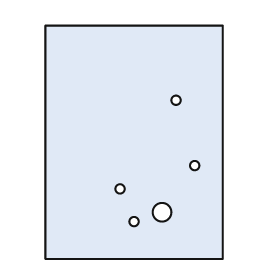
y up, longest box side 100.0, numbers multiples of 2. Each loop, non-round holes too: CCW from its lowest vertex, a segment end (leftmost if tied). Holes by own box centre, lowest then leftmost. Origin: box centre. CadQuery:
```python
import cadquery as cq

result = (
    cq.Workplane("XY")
    .moveTo(-38.0, -50.0)
    .lineTo(38.0, -50.0)
    .lineTo(38.0, 50.0)
    .lineTo(-38.0, 50.0)
    .close()
    .moveTo(0.0, -34.0)
    .circle(2.0)
    .moveTo(12.0, -30.0)
    .circle(4.0)
    .moveTo(-6.0, -20.0)
    .circle(2.0)
    .moveTo(26.0, -10.0)
    .circle(2.0)
    .moveTo(18.0, 18.0)
    .circle(2.0)
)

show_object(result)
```